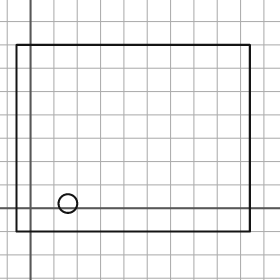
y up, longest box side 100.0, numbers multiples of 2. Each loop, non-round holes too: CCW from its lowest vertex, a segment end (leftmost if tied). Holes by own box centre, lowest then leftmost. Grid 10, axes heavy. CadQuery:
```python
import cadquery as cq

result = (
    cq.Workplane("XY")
    .moveTo(-6.0, -10.0)
    .lineTo(94.0, -10.0)
    .lineTo(94.0, 70.0)
    .lineTo(-6.0, 70.0)
    .close()
    .moveTo(16.0, 2.0)
    .circle(4.0)
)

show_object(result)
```